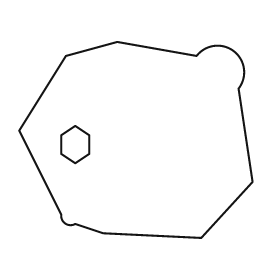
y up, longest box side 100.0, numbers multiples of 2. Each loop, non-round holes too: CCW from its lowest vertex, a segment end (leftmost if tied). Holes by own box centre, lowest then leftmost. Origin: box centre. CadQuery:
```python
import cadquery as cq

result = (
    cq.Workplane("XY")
    .moveTo(28.0, -42.0)
    .lineTo(50.0, -18.0)
    .lineTo(44.0, 22.0)
    .threePointArc((42.0, 38.0), (26.0, 36.0))
    .lineTo(-8.0, 42.0)
    .lineTo(-30.0, 36.0)
    .lineTo(-50.0, 4.0)
    .lineTo(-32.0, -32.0)
    .threePointArc((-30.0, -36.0), (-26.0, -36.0))
    .lineTo(-14.0, -40.0)
    .close()
    .moveTo(-26.0, -10.0)
    .lineTo(-20.0, -6.0)
    .lineTo(-20.0, 2.0)
    .lineTo(-26.0, 6.0)
    .lineTo(-32.0, 2.0)
    .lineTo(-32.0, -6.0)
    .close()
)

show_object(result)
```